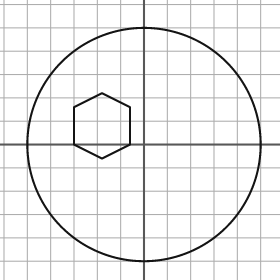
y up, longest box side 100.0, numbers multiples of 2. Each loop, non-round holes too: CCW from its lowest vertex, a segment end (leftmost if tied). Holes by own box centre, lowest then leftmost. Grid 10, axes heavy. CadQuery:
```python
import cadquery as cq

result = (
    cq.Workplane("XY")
    .moveTo(0.0, 0.0)
    .circle(50.0)
    .moveTo(-18.0, -6.0)
    .lineTo(-6.0, 0.0)
    .lineTo(-6.0, 16.0)
    .lineTo(-18.0, 22.0)
    .lineTo(-30.0, 16.0)
    .lineTo(-30.0, 0.0)
    .close()
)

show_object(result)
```